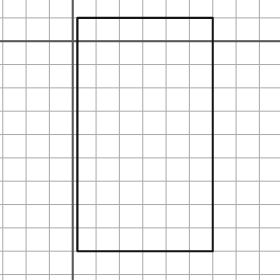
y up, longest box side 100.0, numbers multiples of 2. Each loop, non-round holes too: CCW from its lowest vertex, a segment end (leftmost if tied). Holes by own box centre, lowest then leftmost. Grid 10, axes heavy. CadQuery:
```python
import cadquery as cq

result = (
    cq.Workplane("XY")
    .moveTo(2.0, -90.0)
    .lineTo(60.0, -90.0)
    .lineTo(60.0, 10.0)
    .lineTo(2.0, 10.0)
    .close()
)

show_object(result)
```